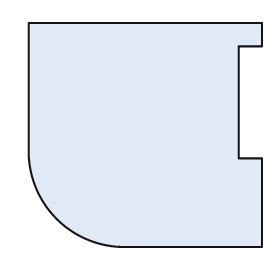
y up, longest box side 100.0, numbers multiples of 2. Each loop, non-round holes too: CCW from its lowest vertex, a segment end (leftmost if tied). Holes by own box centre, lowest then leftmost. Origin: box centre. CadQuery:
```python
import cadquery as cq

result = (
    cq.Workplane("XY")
    .moveTo(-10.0, -48.0)
    .lineTo(50.0, -48.0)
    .lineTo(50.0, -10.0)
    .lineTo(40.0, -10.0)
    .lineTo(40.0, 38.0)
    .lineTo(50.0, 38.0)
    .lineTo(50.0, 48.0)
    .lineTo(-50.0, 48.0)
    .lineTo(-50.0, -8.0)
    .threePointArc((-38.0, -36.0), (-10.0, -48.0))
    .close()
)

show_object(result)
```